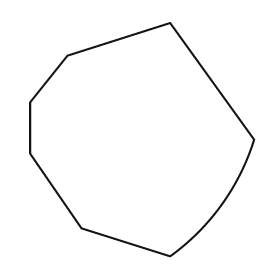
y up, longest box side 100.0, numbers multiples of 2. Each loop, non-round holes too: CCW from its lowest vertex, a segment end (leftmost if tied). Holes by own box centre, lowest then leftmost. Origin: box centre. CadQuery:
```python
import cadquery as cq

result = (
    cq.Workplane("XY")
    .moveTo(12.0, -50.0)
    .threePointArc((34.0, -28.0), (48.0, 0.0))
    .lineTo(12.0, 50.0)
    .lineTo(-32.0, 36.0)
    .lineTo(-48.0, 16.0)
    .lineTo(-48.0, -6.0)
    .lineTo(-26.0, -38.0)
    .close()
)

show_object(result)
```